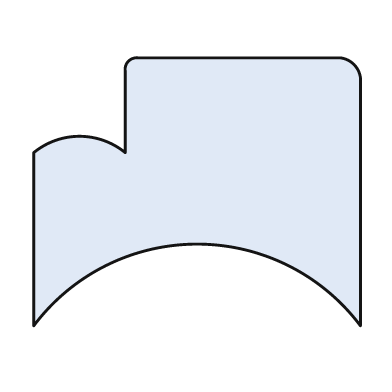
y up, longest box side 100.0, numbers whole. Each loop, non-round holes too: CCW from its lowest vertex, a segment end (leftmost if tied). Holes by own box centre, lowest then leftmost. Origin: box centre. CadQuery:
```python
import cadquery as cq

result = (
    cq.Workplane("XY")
    .moveTo(-50.0, -41.0)
    .threePointArc((0.0, -16.0), (50.0, -41.0))
    .lineTo(50.0, 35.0)
    .threePointArc((48.0, 39.0), (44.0, 41.0))
    .lineTo(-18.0, 41.0)
    .threePointArc((-21.0, 40.0), (-22.0, 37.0))
    .lineTo(-22.0, 12.0)
    .threePointArc((-36.0, 17.0), (-50.0, 12.0))
    .close()
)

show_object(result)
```